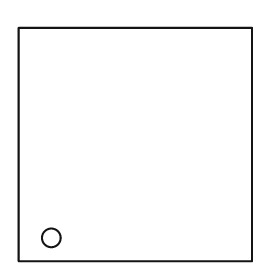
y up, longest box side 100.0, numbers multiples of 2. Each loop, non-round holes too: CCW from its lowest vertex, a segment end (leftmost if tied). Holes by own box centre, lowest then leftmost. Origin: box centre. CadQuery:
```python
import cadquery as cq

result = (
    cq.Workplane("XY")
    .moveTo(-50.0, -50.0)
    .lineTo(50.0, -50.0)
    .lineTo(50.0, 50.0)
    .lineTo(-50.0, 50.0)
    .close()
    .moveTo(-36.0, -40.0)
    .circle(4.0)
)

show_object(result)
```